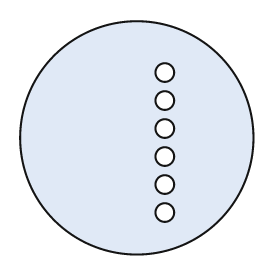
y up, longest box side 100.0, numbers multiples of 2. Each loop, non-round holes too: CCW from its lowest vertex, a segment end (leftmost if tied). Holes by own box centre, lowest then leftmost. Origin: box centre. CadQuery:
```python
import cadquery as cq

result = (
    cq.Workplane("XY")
    .moveTo(0.0, 0.0)
    .circle(50.0)
    .moveTo(12.0, -32.0)
    .circle(4.0)
    .moveTo(12.0, -20.0)
    .circle(4.0)
    .moveTo(12.0, -8.0)
    .circle(4.0)
    .moveTo(12.0, 4.0)
    .circle(4.0)
    .moveTo(12.0, 16.0)
    .circle(4.0)
    .moveTo(12.0, 28.0)
    .circle(4.0)
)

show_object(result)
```